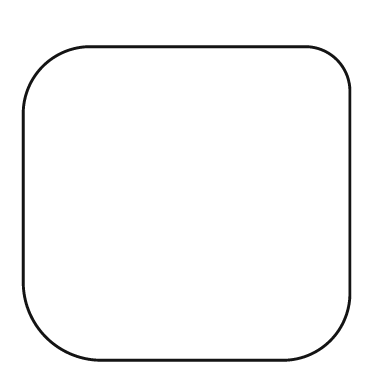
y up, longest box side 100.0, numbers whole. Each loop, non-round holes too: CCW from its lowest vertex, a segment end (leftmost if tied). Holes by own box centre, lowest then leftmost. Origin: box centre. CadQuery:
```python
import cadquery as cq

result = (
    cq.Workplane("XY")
    .moveTo(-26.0, -48.0)
    .lineTo(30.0, -48.0)
    .threePointArc((44.0, -42.0), (50.0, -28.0))
    .lineTo(50.0, 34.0)
    .threePointArc((46.0, 44.0), (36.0, 48.0))
    .lineTo(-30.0, 48.0)
    .threePointArc((-44.0, 42.0), (-50.0, 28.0))
    .lineTo(-50.0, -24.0)
    .threePointArc((-43.0, -41.0), (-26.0, -48.0))
    .close()
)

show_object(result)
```